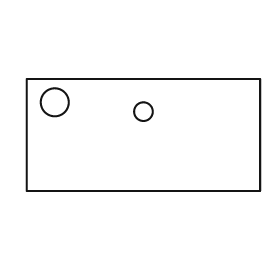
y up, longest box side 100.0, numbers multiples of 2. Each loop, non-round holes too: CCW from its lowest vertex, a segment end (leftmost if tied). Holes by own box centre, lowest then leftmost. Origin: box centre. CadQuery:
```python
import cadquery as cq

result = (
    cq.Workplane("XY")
    .moveTo(-50.0, -24.0)
    .lineTo(50.0, -24.0)
    .lineTo(50.0, 24.0)
    .lineTo(-50.0, 24.0)
    .close()
    .moveTo(0.0, 10.0)
    .circle(4.0)
    .moveTo(-38.0, 14.0)
    .circle(6.0)
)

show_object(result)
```